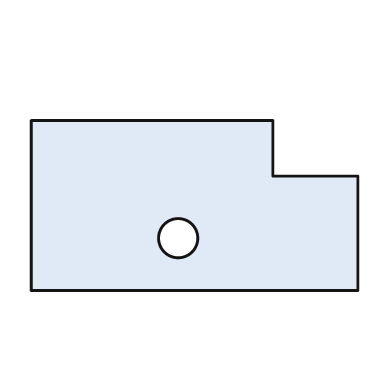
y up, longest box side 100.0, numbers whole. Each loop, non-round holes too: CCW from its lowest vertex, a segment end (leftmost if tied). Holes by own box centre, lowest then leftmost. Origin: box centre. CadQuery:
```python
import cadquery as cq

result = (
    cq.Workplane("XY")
    .moveTo(-50.0, -26.0)
    .lineTo(50.0, -26.0)
    .lineTo(50.0, 9.0)
    .lineTo(24.0, 9.0)
    .lineTo(24.0, 26.0)
    .lineTo(-50.0, 26.0)
    .close()
    .moveTo(-5.0, -10.0)
    .circle(6.0)
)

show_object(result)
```